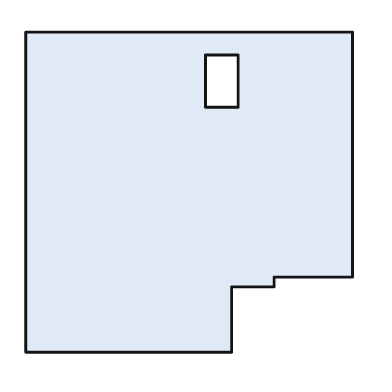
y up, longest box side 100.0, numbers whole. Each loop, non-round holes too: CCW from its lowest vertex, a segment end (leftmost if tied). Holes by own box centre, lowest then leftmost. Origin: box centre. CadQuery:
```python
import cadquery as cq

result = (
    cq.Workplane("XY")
    .moveTo(-50.0, -49.0)
    .lineTo(13.0, -49.0)
    .lineTo(13.0, -29.0)
    .lineTo(26.0, -29.0)
    .lineTo(26.0, -26.0)
    .lineTo(50.0, -26.0)
    .lineTo(50.0, 49.0)
    .lineTo(-50.0, 49.0)
    .close()
    .moveTo(5.0, 26.0)
    .lineTo(15.0, 26.0)
    .lineTo(15.0, 42.0)
    .lineTo(5.0, 42.0)
    .close()
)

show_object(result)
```